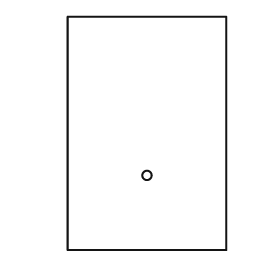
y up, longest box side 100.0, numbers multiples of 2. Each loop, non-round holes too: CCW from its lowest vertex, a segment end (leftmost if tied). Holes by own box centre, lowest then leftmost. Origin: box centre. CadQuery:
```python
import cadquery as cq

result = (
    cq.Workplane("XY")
    .moveTo(-34.0, -50.0)
    .lineTo(34.0, -50.0)
    .lineTo(34.0, 50.0)
    .lineTo(-34.0, 50.0)
    .close()
    .moveTo(0.0, -18.0)
    .circle(2.0)
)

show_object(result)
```